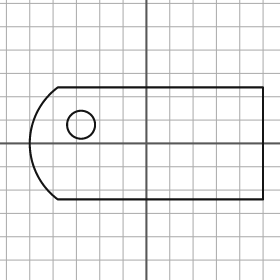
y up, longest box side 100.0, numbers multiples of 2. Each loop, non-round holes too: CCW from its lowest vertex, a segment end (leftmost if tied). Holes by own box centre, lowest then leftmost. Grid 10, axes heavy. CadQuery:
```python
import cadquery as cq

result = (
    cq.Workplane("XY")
    .moveTo(-38.0, -24.0)
    .lineTo(50.0, -24.0)
    .lineTo(50.0, 24.0)
    .lineTo(-38.0, 24.0)
    .threePointArc((-50.0, 0.0), (-38.0, -24.0))
    .close()
    .moveTo(-28.0, 8.0)
    .circle(6.0)
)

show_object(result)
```